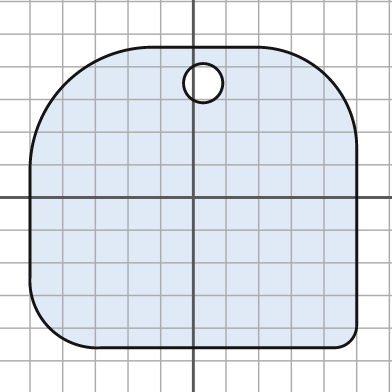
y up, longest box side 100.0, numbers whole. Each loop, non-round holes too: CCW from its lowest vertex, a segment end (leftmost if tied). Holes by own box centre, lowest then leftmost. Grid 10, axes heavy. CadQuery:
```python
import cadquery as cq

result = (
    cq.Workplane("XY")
    .moveTo(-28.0, -46.0)
    .lineTo(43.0, -46.0)
    .threePointArc((48.0, -44.0), (50.0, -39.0))
    .lineTo(50.0, 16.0)
    .threePointArc((41.0, 37.0), (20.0, 46.0))
    .lineTo(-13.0, 46.0)
    .threePointArc((-39.0, 35.0), (-50.0, 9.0))
    .lineTo(-50.0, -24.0)
    .threePointArc((-44.0, -40.0), (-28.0, -46.0))
    .close()
    .moveTo(3.0, 35.0)
    .circle(6.0)
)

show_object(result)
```